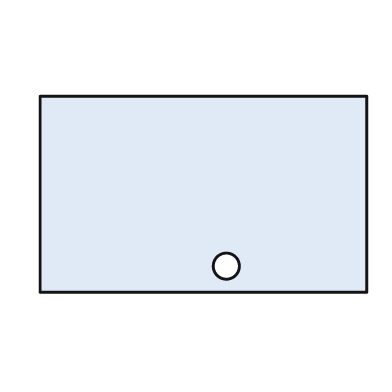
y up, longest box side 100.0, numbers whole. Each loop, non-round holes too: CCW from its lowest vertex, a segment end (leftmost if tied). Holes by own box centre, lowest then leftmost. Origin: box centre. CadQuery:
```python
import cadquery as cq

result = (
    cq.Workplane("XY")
    .moveTo(-50.0, -30.0)
    .lineTo(50.0, -30.0)
    .lineTo(50.0, 30.0)
    .lineTo(-50.0, 30.0)
    .close()
    .moveTo(7.0, -22.0)
    .circle(4.0)
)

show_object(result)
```